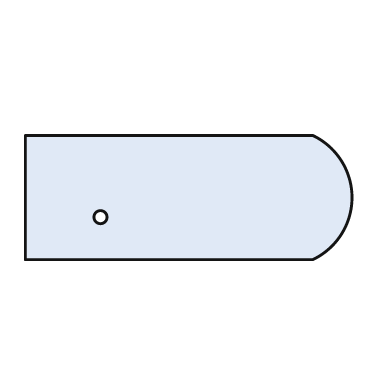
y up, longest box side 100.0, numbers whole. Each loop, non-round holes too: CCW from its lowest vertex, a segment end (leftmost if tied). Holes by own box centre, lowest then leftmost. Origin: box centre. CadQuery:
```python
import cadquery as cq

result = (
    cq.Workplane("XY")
    .moveTo(-50.0, -19.0)
    .lineTo(38.0, -19.0)
    .threePointArc((50.0, 0.0), (38.0, 19.0))
    .lineTo(-50.0, 19.0)
    .close()
    .moveTo(-27.0, -6.0)
    .circle(2.0)
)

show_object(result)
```